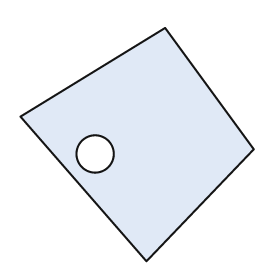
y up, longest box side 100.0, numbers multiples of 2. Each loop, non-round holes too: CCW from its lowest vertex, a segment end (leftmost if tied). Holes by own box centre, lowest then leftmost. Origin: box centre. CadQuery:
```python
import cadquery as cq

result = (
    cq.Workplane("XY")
    .moveTo(4.0, -50.0)
    .lineTo(50.0, -2.0)
    .lineTo(12.0, 50.0)
    .lineTo(-50.0, 12.0)
    .close()
    .moveTo(-18.0, -4.0)
    .circle(8.0)
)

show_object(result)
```